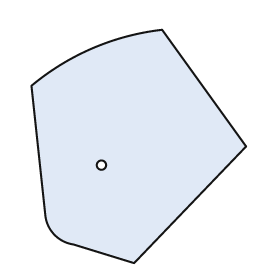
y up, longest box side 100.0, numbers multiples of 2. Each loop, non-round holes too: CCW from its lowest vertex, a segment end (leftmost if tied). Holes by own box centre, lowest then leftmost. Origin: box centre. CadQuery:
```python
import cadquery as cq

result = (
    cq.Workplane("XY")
    .moveTo(-2.0, -50.0)
    .lineTo(46.0, 0.0)
    .lineTo(10.0, 50.0)
    .threePointArc((-20.0, 42.0), (-46.0, 26.0))
    .lineTo(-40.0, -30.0)
    .threePointArc((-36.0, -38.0), (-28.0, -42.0))
    .close()
    .moveTo(-16.0, -8.0)
    .circle(2.0)
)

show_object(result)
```